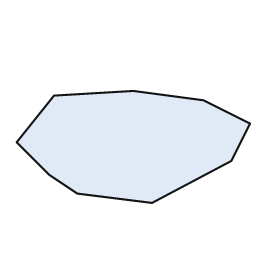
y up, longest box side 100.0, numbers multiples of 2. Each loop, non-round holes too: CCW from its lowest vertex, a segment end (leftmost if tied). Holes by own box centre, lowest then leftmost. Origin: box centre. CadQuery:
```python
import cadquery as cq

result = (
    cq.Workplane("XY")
    .moveTo(8.0, -24.0)
    .lineTo(42.0, -6.0)
    .lineTo(50.0, 10.0)
    .lineTo(30.0, 20.0)
    .lineTo(0.0, 24.0)
    .lineTo(-34.0, 22.0)
    .lineTo(-50.0, 2.0)
    .lineTo(-36.0, -12.0)
    .lineTo(-24.0, -20.0)
    .close()
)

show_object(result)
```